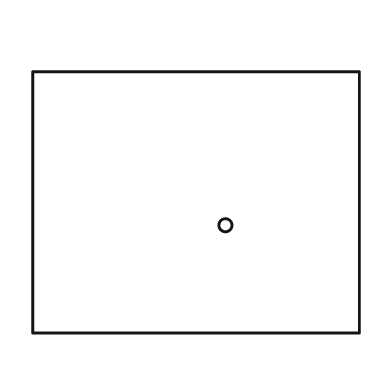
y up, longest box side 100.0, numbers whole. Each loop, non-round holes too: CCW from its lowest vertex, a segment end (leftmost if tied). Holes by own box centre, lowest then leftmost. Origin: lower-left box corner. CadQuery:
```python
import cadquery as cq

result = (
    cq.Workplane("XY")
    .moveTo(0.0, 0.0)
    .lineTo(100.0, 0.0)
    .lineTo(100.0, 80.0)
    .lineTo(0.0, 80.0)
    .close()
    .moveTo(59.0, 33.0)
    .circle(2.0)
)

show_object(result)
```